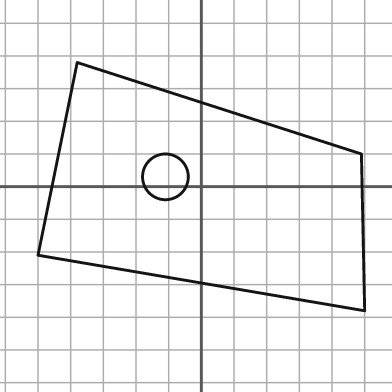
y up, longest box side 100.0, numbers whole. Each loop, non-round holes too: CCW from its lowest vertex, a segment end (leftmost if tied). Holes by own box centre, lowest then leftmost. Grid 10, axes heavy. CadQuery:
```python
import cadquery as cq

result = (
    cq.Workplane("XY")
    .moveTo(50.0, -38.0)
    .lineTo(49.0, 10.0)
    .lineTo(-38.0, 38.0)
    .lineTo(-50.0, -21.0)
    .close()
    .moveTo(-11.0, 3.0)
    .circle(7.0)
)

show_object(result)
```